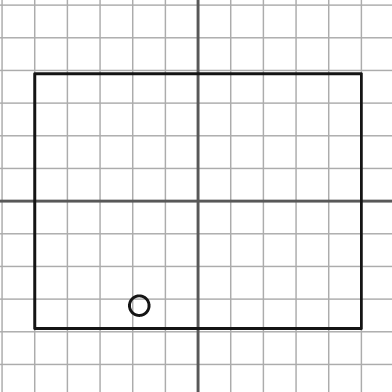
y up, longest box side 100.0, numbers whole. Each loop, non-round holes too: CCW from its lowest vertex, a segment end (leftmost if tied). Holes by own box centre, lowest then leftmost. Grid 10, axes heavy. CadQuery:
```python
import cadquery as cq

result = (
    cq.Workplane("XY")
    .moveTo(-50.0, -39.0)
    .lineTo(50.0, -39.0)
    .lineTo(50.0, 39.0)
    .lineTo(-50.0, 39.0)
    .close()
    .moveTo(-18.0, -32.0)
    .circle(3.0)
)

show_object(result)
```